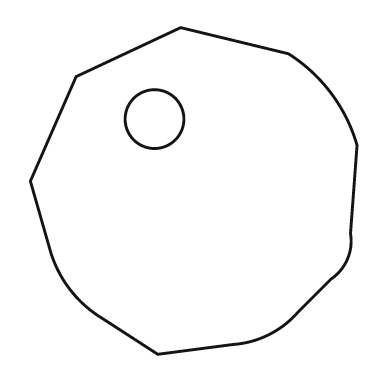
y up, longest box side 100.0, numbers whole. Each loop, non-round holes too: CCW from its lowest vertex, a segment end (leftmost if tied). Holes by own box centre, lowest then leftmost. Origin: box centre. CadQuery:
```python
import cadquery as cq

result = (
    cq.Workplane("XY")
    .moveTo(-11.0, -50.0)
    .lineTo(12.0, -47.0)
    .threePointArc((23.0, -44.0), (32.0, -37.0))
    .lineTo(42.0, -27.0)
    .threePointArc((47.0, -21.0), (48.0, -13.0))
    .lineTo(50.0, 14.0)
    .threePointArc((42.0, 30.0), (29.0, 42.0))
    .lineTo(-4.0, 50.0)
    .lineTo(-36.0, 35.0)
    .lineTo(-50.0, 3.0)
    .lineTo(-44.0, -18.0)
    .threePointArc((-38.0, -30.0), (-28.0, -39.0))
    .close()
    .moveTo(-12.0, 22.0)
    .circle(9.0)
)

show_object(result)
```